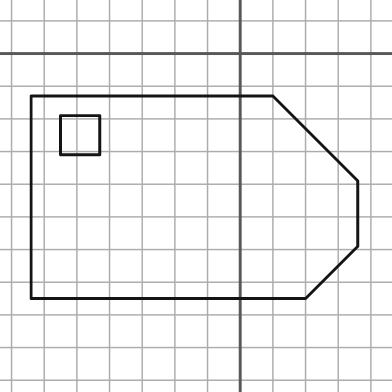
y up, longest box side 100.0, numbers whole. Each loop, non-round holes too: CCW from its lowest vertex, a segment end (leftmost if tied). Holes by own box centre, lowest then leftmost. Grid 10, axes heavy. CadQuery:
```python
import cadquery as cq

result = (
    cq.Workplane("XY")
    .moveTo(-64.0, -75.0)
    .lineTo(20.0, -75.0)
    .lineTo(36.0, -59.0)
    .lineTo(36.0, -39.0)
    .lineTo(10.0, -13.0)
    .lineTo(-64.0, -13.0)
    .close()
    .moveTo(-55.0, -31.0)
    .lineTo(-43.0, -31.0)
    .lineTo(-43.0, -19.0)
    .lineTo(-55.0, -19.0)
    .close()
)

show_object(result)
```